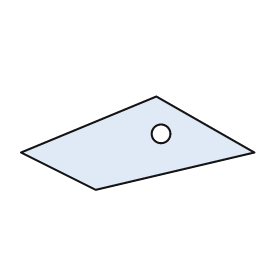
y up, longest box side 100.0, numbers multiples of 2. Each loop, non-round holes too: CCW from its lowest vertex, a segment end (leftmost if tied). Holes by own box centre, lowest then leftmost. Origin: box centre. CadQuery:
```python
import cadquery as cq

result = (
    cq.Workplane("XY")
    .moveTo(-18.0, -20.0)
    .lineTo(50.0, -4.0)
    .lineTo(8.0, 20.0)
    .lineTo(-50.0, -4.0)
    .close()
    .moveTo(10.0, 4.0)
    .circle(4.0)
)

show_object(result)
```